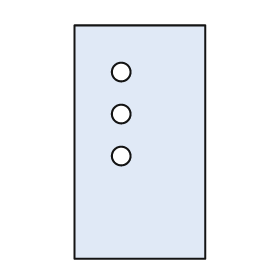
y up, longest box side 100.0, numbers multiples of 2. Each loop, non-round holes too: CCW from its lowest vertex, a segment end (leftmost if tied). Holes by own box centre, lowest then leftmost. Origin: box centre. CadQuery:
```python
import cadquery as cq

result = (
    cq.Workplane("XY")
    .moveTo(-28.0, -50.0)
    .lineTo(28.0, -50.0)
    .lineTo(28.0, 50.0)
    .lineTo(-28.0, 50.0)
    .close()
    .moveTo(-8.0, -6.0)
    .circle(4.0)
    .moveTo(-8.0, 12.0)
    .circle(4.0)
    .moveTo(-8.0, 30.0)
    .circle(4.0)
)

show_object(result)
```